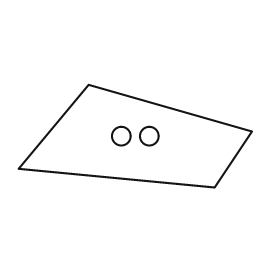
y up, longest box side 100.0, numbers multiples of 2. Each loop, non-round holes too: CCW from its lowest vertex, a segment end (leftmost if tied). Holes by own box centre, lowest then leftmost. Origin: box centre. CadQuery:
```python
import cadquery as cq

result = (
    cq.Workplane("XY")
    .moveTo(34.0, -22.0)
    .lineTo(50.0, 2.0)
    .lineTo(-20.0, 22.0)
    .lineTo(-50.0, -14.0)
    .close()
    .moveTo(-6.0, 0.0)
    .circle(4.0)
    .moveTo(6.0, 0.0)
    .circle(4.0)
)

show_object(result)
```